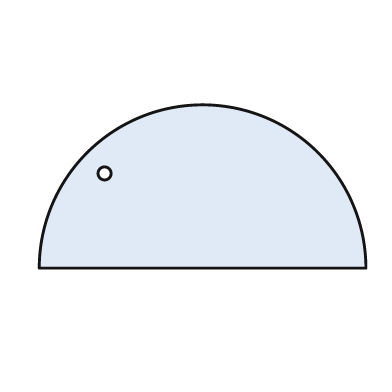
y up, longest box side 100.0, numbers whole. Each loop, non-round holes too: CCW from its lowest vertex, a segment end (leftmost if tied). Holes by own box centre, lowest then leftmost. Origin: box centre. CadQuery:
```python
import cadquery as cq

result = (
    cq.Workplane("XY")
    .moveTo(-50.0, -25.0)
    .lineTo(50.0, -25.0)
    .threePointArc((0.0, 25.0), (-50.0, -25.0))
    .close()
    .moveTo(-30.0, 4.0)
    .circle(2.0)
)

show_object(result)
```